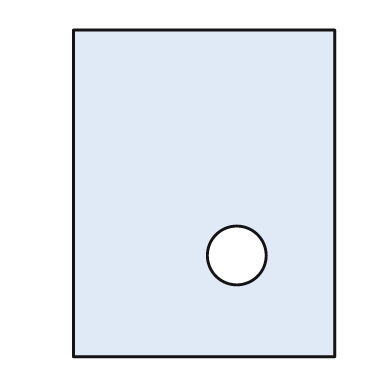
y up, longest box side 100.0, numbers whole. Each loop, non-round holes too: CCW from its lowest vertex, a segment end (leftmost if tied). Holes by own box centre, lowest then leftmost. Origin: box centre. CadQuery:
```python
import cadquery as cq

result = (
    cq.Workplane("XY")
    .moveTo(-40.0, -50.0)
    .lineTo(40.0, -50.0)
    .lineTo(40.0, 50.0)
    .lineTo(-40.0, 50.0)
    .close()
    .moveTo(10.0, -19.0)
    .circle(9.0)
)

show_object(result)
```